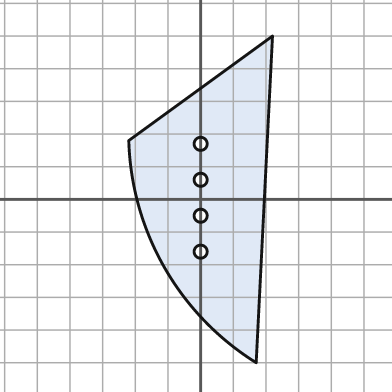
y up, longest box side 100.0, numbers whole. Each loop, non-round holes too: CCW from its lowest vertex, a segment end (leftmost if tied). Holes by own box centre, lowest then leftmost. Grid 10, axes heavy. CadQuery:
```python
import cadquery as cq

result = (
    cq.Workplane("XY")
    .moveTo(17.0, -50.0)
    .lineTo(22.0, 50.0)
    .lineTo(-22.0, 18.0)
    .threePointArc((-11.0, -21.0), (17.0, -50.0))
    .close()
    .moveTo(0.0, -16.0)
    .circle(2.0)
    .moveTo(0.0, -5.0)
    .circle(2.0)
    .moveTo(0.0, 6.0)
    .circle(2.0)
    .moveTo(0.0, 17.0)
    .circle(2.0)
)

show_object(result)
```